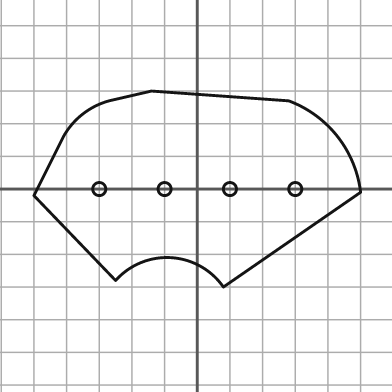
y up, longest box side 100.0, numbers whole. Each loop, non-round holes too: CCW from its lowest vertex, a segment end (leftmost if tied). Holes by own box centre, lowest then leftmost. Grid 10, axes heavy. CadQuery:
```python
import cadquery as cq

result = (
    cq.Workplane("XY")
    .moveTo(8.0, -30.0)
    .lineTo(50.0, -1.0)
    .threePointArc((43.0, 16.0), (28.0, 27.0))
    .lineTo(-14.0, 30.0)
    .lineTo(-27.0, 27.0)
    .threePointArc((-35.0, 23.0), (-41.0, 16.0))
    .lineTo(-50.0, -2.0)
    .lineTo(-25.0, -28.0)
    .threePointArc((-8.0, -21.0), (8.0, -30.0))
    .close()
    .moveTo(-30.0, 0.0)
    .circle(2.0)
    .moveTo(-10.0, 0.0)
    .circle(2.0)
    .moveTo(10.0, 0.0)
    .circle(2.0)
    .moveTo(30.0, 0.0)
    .circle(2.0)
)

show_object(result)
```